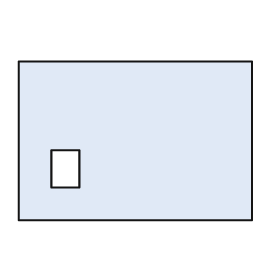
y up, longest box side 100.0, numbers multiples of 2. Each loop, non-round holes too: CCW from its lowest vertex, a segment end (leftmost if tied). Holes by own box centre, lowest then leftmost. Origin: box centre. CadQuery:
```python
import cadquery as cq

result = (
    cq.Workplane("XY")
    .moveTo(-50.0, -34.0)
    .lineTo(50.0, -34.0)
    .lineTo(50.0, 34.0)
    .lineTo(-50.0, 34.0)
    .close()
    .moveTo(-36.0, -20.0)
    .lineTo(-24.0, -20.0)
    .lineTo(-24.0, -4.0)
    .lineTo(-36.0, -4.0)
    .close()
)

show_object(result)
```